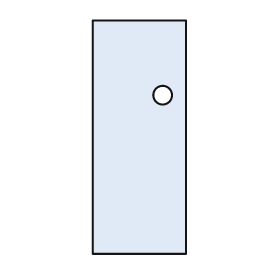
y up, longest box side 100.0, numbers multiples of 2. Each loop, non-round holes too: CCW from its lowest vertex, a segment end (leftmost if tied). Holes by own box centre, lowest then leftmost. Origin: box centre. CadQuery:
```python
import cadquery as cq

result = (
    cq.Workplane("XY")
    .moveTo(-20.0, -50.0)
    .lineTo(20.0, -50.0)
    .lineTo(20.0, 50.0)
    .lineTo(-20.0, 50.0)
    .close()
    .moveTo(10.0, 18.0)
    .circle(4.0)
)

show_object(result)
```